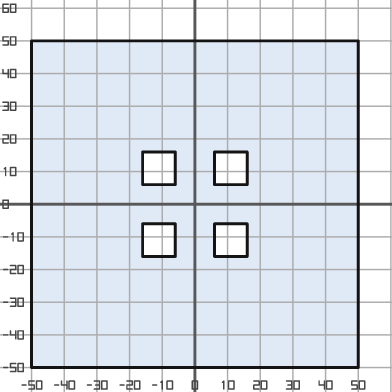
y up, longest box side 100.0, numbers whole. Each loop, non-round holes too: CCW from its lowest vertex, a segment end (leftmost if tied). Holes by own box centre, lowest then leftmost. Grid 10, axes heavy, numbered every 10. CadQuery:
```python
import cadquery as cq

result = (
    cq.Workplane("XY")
    .moveTo(-50.0, -50.0)
    .lineTo(50.0, -50.0)
    .lineTo(50.0, 50.0)
    .lineTo(-50.0, 50.0)
    .close()
    .moveTo(-16.0, -16.0)
    .lineTo(-6.0, -16.0)
    .lineTo(-6.0, -6.0)
    .lineTo(-16.0, -6.0)
    .close()
    .moveTo(6.0, -16.0)
    .lineTo(16.0, -16.0)
    .lineTo(16.0, -6.0)
    .lineTo(6.0, -6.0)
    .close()
    .moveTo(-16.0, 6.0)
    .lineTo(-6.0, 6.0)
    .lineTo(-6.0, 16.0)
    .lineTo(-16.0, 16.0)
    .close()
    .moveTo(6.0, 6.0)
    .lineTo(16.0, 6.0)
    .lineTo(16.0, 16.0)
    .lineTo(6.0, 16.0)
    .close()
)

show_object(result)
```